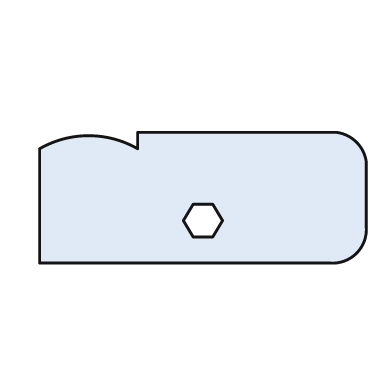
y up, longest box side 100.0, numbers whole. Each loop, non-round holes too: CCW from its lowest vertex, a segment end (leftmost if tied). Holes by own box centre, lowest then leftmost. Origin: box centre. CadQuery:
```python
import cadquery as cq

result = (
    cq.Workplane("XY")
    .moveTo(-50.0, -20.0)
    .lineTo(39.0, -20.0)
    .threePointArc((47.0, -17.0), (50.0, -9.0))
    .lineTo(50.0, 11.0)
    .threePointArc((47.0, 17.0), (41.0, 20.0))
    .lineTo(-20.0, 20.0)
    .lineTo(-20.0, 15.0)
    .threePointArc((-35.0, 19.0), (-50.0, 15.0))
    .close()
    .moveTo(-3.0, -12.0)
    .lineTo(3.0, -12.0)
    .lineTo(6.0, -7.0)
    .lineTo(3.0, -2.0)
    .lineTo(-3.0, -2.0)
    .lineTo(-6.0, -7.0)
    .close()
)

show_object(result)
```